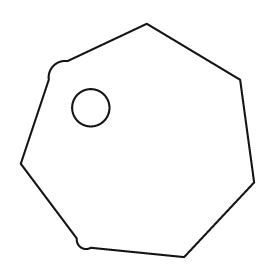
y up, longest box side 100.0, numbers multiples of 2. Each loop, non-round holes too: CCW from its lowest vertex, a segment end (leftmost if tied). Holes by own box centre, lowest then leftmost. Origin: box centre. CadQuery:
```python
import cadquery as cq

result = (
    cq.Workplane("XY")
    .moveTo(20.0, -50.0)
    .lineTo(50.0, -18.0)
    .lineTo(44.0, 26.0)
    .lineTo(4.0, 50.0)
    .lineTo(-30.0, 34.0)
    .threePointArc((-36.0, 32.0), (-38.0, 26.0))
    .lineTo(-50.0, -10.0)
    .lineTo(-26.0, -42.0)
    .threePointArc((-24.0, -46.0), (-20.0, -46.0))
    .close()
    .moveTo(-20.0, 14.0)
    .circle(8.0)
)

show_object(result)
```